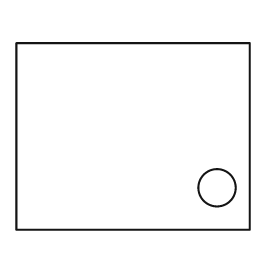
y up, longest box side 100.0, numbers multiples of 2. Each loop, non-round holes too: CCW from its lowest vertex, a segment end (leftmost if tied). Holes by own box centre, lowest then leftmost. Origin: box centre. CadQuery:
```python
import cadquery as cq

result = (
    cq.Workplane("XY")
    .moveTo(-50.0, -40.0)
    .lineTo(50.0, -40.0)
    .lineTo(50.0, 40.0)
    .lineTo(-50.0, 40.0)
    .close()
    .moveTo(36.0, -22.0)
    .circle(8.0)
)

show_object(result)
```